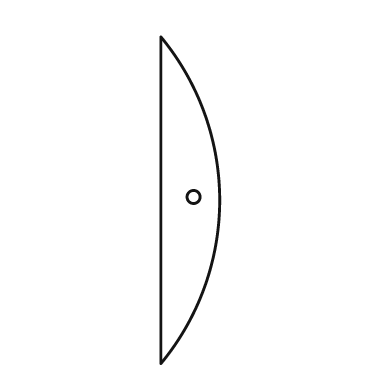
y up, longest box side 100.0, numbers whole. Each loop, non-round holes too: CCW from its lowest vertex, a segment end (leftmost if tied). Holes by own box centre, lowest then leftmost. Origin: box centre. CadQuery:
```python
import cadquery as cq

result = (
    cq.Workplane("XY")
    .moveTo(-9.0, -50.0)
    .threePointArc((9.0, 0.0), (-9.0, 50.0))
    .close()
    .moveTo(1.0, 1.0)
    .circle(2.0)
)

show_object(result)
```